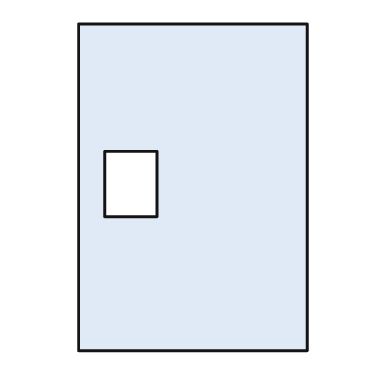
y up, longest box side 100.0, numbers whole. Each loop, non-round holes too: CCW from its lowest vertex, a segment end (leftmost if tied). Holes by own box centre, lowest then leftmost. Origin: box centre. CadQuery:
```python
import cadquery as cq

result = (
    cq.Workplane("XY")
    .moveTo(-35.0, -50.0)
    .lineTo(35.0, -50.0)
    .lineTo(35.0, 50.0)
    .lineTo(-35.0, 50.0)
    .close()
    .moveTo(-27.0, -9.0)
    .lineTo(-11.0, -9.0)
    .lineTo(-11.0, 11.0)
    .lineTo(-27.0, 11.0)
    .close()
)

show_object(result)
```